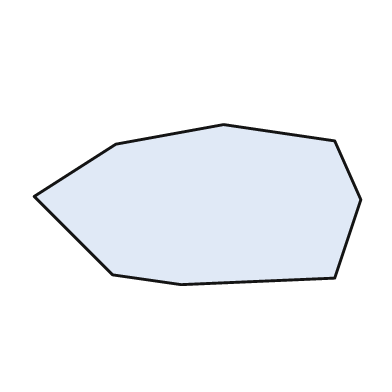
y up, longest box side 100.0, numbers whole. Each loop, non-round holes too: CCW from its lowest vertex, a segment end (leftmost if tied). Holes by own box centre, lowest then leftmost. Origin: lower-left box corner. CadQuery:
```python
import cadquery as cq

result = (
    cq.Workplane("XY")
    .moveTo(45.0, 0.0)
    .lineTo(92.0, 2.0)
    .lineTo(100.0, 26.0)
    .lineTo(92.0, 44.0)
    .lineTo(58.0, 49.0)
    .lineTo(25.0, 43.0)
    .lineTo(0.0, 27.0)
    .lineTo(24.0, 3.0)
    .close()
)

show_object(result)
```